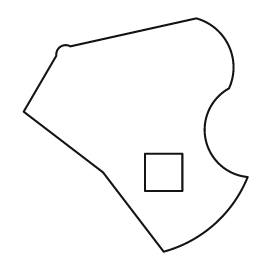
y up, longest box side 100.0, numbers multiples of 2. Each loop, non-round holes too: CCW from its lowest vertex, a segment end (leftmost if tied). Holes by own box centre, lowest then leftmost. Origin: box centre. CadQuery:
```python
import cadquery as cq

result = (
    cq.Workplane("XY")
    .moveTo(12.0, -50.0)
    .threePointArc((34.0, -38.0), (48.0, -18.0))
    .threePointArc((30.0, -2.0), (40.0, 20.0))
    .threePointArc((40.0, 38.0), (26.0, 50.0))
    .lineTo(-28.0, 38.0)
    .threePointArc((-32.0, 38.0), (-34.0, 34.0))
    .lineTo(-48.0, 10.0)
    .lineTo(-14.0, -16.0)
    .close()
    .moveTo(4.0, -24.0)
    .lineTo(20.0, -24.0)
    .lineTo(20.0, -8.0)
    .lineTo(4.0, -8.0)
    .close()
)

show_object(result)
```